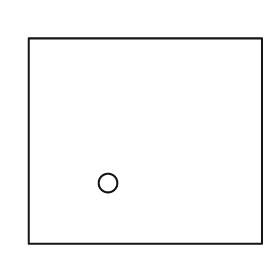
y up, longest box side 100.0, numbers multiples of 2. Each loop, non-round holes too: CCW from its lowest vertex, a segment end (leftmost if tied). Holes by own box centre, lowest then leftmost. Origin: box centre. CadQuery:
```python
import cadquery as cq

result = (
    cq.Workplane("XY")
    .moveTo(-50.0, -44.0)
    .lineTo(50.0, -44.0)
    .lineTo(50.0, 44.0)
    .lineTo(-50.0, 44.0)
    .close()
    .moveTo(-16.0, -18.0)
    .circle(4.0)
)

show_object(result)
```